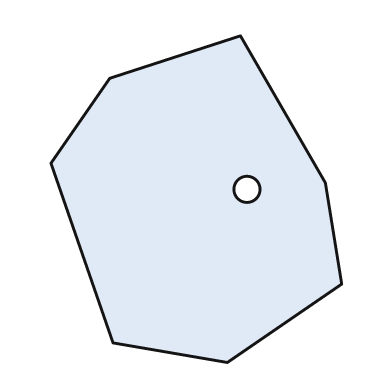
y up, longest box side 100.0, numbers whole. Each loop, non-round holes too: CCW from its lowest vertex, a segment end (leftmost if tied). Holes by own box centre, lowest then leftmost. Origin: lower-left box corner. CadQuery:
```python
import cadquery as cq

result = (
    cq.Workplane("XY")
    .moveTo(54.0, 0.0)
    .lineTo(89.0, 24.0)
    .lineTo(84.0, 55.0)
    .lineTo(58.0, 100.0)
    .lineTo(18.0, 87.0)
    .lineTo(0.0, 61.0)
    .lineTo(19.0, 6.0)
    .close()
    .moveTo(60.0, 53.0)
    .circle(4.0)
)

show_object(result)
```